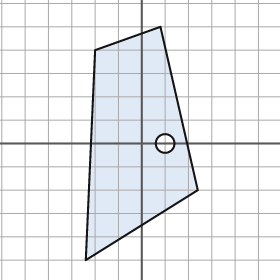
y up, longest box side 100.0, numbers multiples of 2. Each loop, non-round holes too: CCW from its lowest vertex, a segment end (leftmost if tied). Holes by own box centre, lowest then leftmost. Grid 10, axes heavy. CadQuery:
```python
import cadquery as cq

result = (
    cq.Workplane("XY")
    .moveTo(-24.0, -50.0)
    .lineTo(24.0, -20.0)
    .lineTo(8.0, 50.0)
    .lineTo(-20.0, 40.0)
    .close()
    .moveTo(10.0, 0.0)
    .circle(4.0)
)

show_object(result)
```